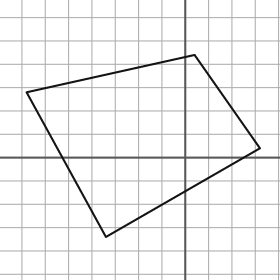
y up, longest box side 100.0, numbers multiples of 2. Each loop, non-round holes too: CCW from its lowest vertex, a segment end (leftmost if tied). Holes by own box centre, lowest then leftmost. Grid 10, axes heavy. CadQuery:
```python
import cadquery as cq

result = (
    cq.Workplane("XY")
    .moveTo(-34.0, -34.0)
    .lineTo(32.0, 4.0)
    .lineTo(4.0, 44.0)
    .lineTo(-68.0, 28.0)
    .close()
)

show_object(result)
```